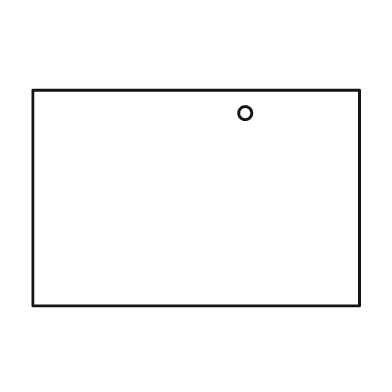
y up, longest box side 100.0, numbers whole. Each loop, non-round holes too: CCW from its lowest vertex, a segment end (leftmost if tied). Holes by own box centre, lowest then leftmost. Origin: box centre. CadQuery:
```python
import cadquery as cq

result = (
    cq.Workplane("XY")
    .moveTo(-50.0, -33.0)
    .lineTo(50.0, -33.0)
    .lineTo(50.0, 33.0)
    .lineTo(-50.0, 33.0)
    .close()
    .moveTo(15.0, 26.0)
    .circle(2.0)
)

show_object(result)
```